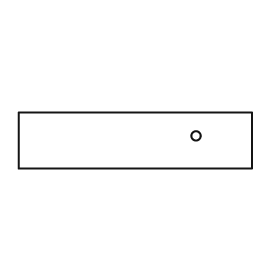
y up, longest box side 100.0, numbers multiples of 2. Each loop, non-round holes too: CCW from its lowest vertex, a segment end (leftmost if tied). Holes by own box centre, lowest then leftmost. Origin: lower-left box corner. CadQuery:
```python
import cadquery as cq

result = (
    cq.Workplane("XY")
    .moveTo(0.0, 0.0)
    .lineTo(100.0, 0.0)
    .lineTo(100.0, 24.0)
    .lineTo(0.0, 24.0)
    .close()
    .moveTo(76.0, 14.0)
    .circle(2.0)
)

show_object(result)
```